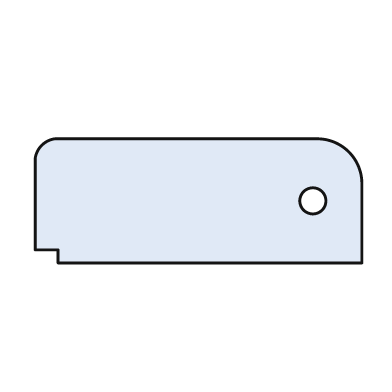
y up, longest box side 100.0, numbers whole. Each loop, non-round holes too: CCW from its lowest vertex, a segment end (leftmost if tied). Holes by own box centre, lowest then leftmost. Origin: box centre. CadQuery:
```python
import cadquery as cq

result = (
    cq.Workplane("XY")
    .moveTo(-43.0, -19.0)
    .lineTo(50.0, -19.0)
    .lineTo(50.0, 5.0)
    .threePointArc((46.0, 15.0), (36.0, 19.0))
    .lineTo(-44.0, 19.0)
    .threePointArc((-48.0, 17.0), (-50.0, 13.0))
    .lineTo(-50.0, -15.0)
    .lineTo(-43.0, -15.0)
    .close()
    .moveTo(35.0, 0.0)
    .circle(4.0)
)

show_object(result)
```